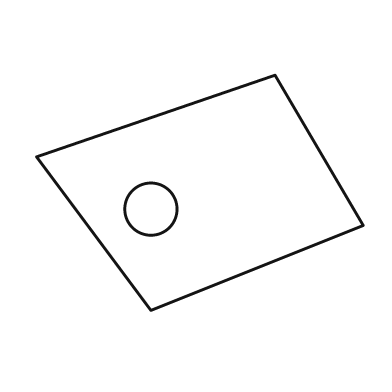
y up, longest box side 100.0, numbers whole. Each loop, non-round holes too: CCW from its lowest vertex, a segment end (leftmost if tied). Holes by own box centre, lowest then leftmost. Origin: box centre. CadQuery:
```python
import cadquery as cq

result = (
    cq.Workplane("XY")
    .moveTo(-15.0, -36.0)
    .lineTo(50.0, -10.0)
    .lineTo(23.0, 36.0)
    .lineTo(-50.0, 11.0)
    .close()
    .moveTo(-15.0, -5.0)
    .circle(8.0)
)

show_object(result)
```